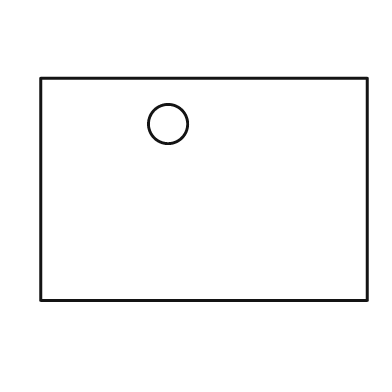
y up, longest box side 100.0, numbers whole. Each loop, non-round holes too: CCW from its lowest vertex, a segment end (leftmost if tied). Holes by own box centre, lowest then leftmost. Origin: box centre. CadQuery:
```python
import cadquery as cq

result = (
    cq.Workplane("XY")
    .moveTo(-50.0, -34.0)
    .lineTo(50.0, -34.0)
    .lineTo(50.0, 34.0)
    .lineTo(-50.0, 34.0)
    .close()
    .moveTo(-11.0, 20.0)
    .circle(6.0)
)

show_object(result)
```